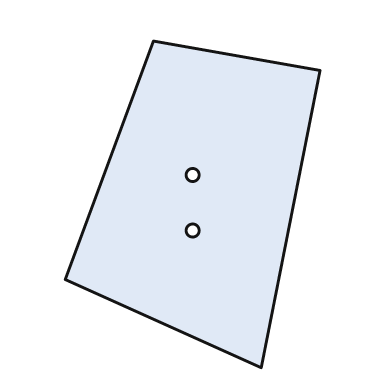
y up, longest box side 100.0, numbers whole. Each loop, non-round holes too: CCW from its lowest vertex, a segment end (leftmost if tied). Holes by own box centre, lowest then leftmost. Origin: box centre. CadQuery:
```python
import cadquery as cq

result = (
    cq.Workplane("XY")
    .moveTo(21.0, -50.0)
    .lineTo(39.0, 41.0)
    .lineTo(-12.0, 50.0)
    .lineTo(-39.0, -23.0)
    .close()
    .moveTo(0.0, -8.0)
    .circle(2.0)
    .moveTo(0.0, 9.0)
    .circle(2.0)
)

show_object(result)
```